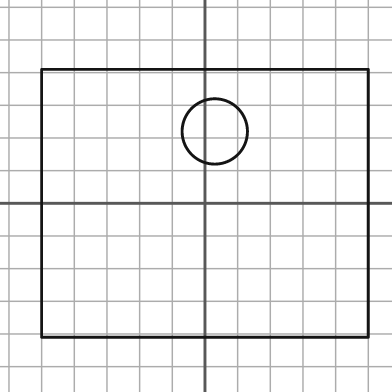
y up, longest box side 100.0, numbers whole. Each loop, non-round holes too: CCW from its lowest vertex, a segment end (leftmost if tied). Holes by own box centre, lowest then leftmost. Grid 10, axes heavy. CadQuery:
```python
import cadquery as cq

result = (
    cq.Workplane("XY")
    .moveTo(-50.0, -41.0)
    .lineTo(50.0, -41.0)
    .lineTo(50.0, 41.0)
    .lineTo(-50.0, 41.0)
    .close()
    .moveTo(3.0, 22.0)
    .circle(10.0)
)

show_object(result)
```